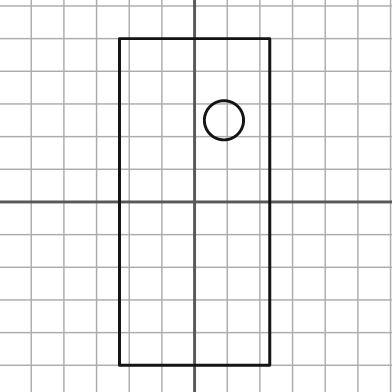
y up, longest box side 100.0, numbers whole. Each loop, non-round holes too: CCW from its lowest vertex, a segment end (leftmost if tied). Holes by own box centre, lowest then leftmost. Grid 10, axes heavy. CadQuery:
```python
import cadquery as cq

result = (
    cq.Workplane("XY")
    .moveTo(-23.0, -50.0)
    .lineTo(23.0, -50.0)
    .lineTo(23.0, 50.0)
    .lineTo(-23.0, 50.0)
    .close()
    .moveTo(9.0, 25.0)
    .circle(6.0)
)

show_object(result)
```